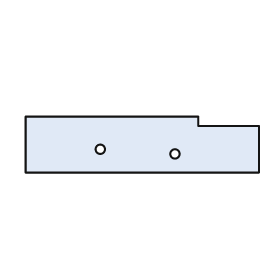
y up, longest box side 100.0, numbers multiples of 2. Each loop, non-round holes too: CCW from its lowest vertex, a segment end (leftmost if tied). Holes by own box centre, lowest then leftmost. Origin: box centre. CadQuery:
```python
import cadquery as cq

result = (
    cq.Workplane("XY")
    .moveTo(-50.0, -12.0)
    .lineTo(50.0, -12.0)
    .lineTo(50.0, 8.0)
    .lineTo(24.0, 8.0)
    .lineTo(24.0, 12.0)
    .lineTo(-50.0, 12.0)
    .close()
    .moveTo(14.0, -4.0)
    .circle(2.0)
    .moveTo(-18.0, -2.0)
    .circle(2.0)
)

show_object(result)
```